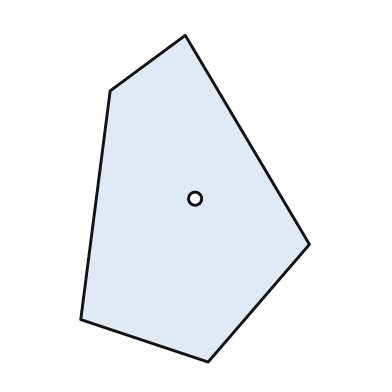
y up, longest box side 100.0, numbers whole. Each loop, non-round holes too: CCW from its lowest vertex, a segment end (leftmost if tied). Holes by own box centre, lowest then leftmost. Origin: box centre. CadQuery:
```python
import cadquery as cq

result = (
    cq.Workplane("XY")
    .moveTo(4.0, -50.0)
    .lineTo(35.0, -14.0)
    .lineTo(-3.0, 50.0)
    .lineTo(-26.0, 33.0)
    .lineTo(-35.0, -37.0)
    .close()
    .moveTo(0.0, 0.0)
    .circle(2.0)
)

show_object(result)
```